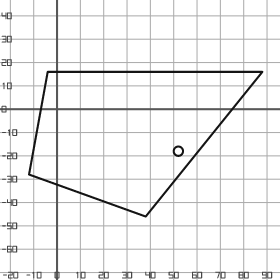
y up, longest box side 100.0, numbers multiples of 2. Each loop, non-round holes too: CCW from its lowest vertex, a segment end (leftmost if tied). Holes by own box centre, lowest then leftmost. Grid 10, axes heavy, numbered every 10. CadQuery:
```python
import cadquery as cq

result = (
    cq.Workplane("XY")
    .moveTo(38.0, -46.0)
    .lineTo(88.0, 16.0)
    .lineTo(-4.0, 16.0)
    .lineTo(-12.0, -28.0)
    .close()
    .moveTo(52.0, -18.0)
    .circle(2.0)
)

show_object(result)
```